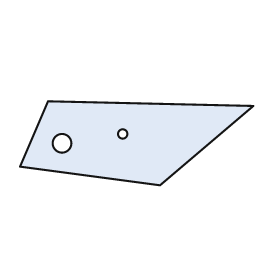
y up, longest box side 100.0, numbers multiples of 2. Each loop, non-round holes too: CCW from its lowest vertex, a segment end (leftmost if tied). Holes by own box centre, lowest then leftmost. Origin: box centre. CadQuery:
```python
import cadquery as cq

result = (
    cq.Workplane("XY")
    .moveTo(10.0, -18.0)
    .lineTo(50.0, 16.0)
    .lineTo(-38.0, 18.0)
    .lineTo(-50.0, -10.0)
    .close()
    .moveTo(-32.0, 0.0)
    .circle(4.0)
    .moveTo(-6.0, 4.0)
    .circle(2.0)
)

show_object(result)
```